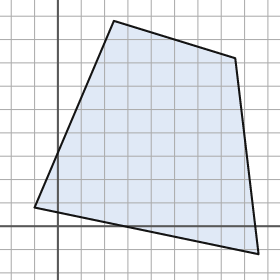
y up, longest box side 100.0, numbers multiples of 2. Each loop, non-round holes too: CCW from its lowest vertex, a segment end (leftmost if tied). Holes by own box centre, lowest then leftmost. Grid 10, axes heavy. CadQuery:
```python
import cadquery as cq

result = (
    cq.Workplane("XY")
    .moveTo(86.0, -12.0)
    .lineTo(76.0, 72.0)
    .lineTo(24.0, 88.0)
    .lineTo(-10.0, 8.0)
    .close()
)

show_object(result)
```